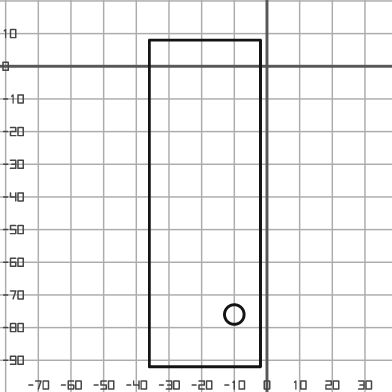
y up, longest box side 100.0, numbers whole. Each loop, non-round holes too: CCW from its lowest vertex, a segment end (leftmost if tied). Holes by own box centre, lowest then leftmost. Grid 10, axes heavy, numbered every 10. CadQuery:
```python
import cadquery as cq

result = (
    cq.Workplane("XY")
    .moveTo(-36.0, -92.0)
    .lineTo(-2.0, -92.0)
    .lineTo(-2.0, 8.0)
    .lineTo(-36.0, 8.0)
    .close()
    .moveTo(-10.0, -76.0)
    .circle(3.0)
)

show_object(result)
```